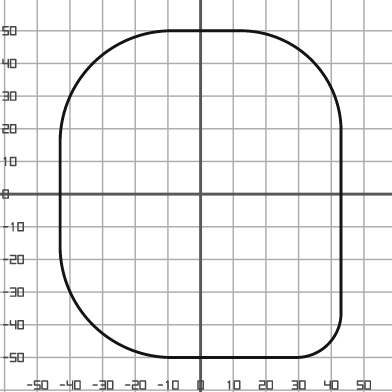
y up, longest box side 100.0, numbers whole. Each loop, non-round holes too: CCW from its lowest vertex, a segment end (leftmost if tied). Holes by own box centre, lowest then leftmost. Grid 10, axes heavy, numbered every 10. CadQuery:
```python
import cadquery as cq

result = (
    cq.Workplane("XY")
    .moveTo(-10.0, -50.0)
    .lineTo(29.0, -50.0)
    .threePointArc((39.0, -46.0), (43.0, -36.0))
    .lineTo(43.0, 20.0)
    .threePointArc((34.0, 41.0), (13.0, 50.0))
    .lineTo(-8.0, 50.0)
    .threePointArc((-33.0, 40.0), (-43.0, 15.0))
    .lineTo(-43.0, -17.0)
    .threePointArc((-33.0, -40.0), (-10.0, -50.0))
    .close()
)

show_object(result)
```